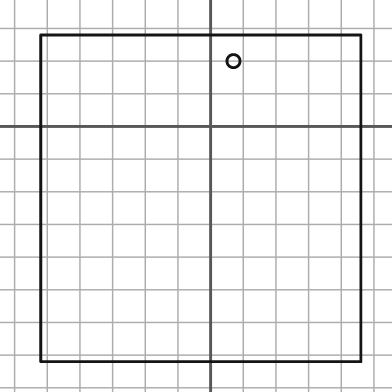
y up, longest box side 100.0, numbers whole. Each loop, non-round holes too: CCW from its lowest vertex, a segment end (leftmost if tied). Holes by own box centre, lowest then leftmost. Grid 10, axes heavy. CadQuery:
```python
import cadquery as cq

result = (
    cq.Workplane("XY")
    .moveTo(-52.0, -72.0)
    .lineTo(46.0, -72.0)
    .lineTo(46.0, 28.0)
    .lineTo(-52.0, 28.0)
    .close()
    .moveTo(7.0, 20.0)
    .circle(2.0)
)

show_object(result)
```